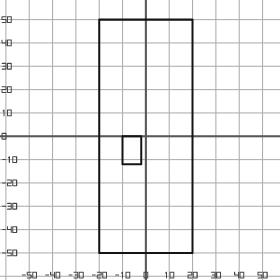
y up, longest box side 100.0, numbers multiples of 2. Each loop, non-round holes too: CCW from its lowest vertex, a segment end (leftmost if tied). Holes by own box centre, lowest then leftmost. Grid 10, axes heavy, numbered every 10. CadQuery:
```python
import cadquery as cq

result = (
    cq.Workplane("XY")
    .moveTo(-20.0, -50.0)
    .lineTo(20.0, -50.0)
    .lineTo(20.0, 50.0)
    .lineTo(-20.0, 50.0)
    .close()
    .moveTo(-10.0, -12.0)
    .lineTo(-2.0, -12.0)
    .lineTo(-2.0, 0.0)
    .lineTo(-10.0, 0.0)
    .close()
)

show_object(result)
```